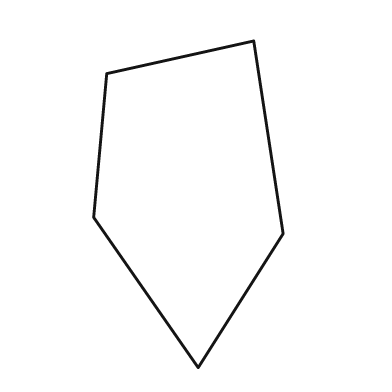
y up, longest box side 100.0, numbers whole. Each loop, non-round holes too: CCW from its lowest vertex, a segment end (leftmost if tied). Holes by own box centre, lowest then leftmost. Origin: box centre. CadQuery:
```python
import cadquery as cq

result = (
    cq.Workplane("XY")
    .moveTo(3.0, -50.0)
    .lineTo(29.0, -9.0)
    .lineTo(20.0, 50.0)
    .lineTo(-25.0, 40.0)
    .lineTo(-29.0, -4.0)
    .close()
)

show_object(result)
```